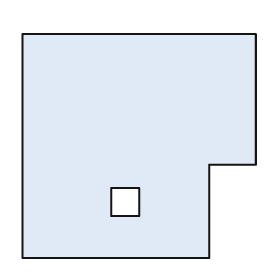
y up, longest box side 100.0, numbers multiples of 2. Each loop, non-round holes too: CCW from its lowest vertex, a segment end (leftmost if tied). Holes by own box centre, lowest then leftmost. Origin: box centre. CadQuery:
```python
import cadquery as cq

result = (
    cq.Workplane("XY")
    .moveTo(-50.0, -48.0)
    .lineTo(30.0, -48.0)
    .lineTo(30.0, -8.0)
    .lineTo(50.0, -8.0)
    .lineTo(50.0, 48.0)
    .lineTo(-50.0, 48.0)
    .close()
    .moveTo(-12.0, -30.0)
    .lineTo(0.0, -30.0)
    .lineTo(0.0, -18.0)
    .lineTo(-12.0, -18.0)
    .close()
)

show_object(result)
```